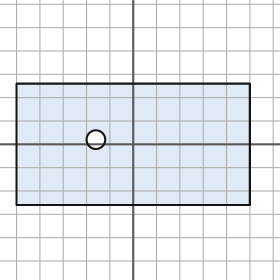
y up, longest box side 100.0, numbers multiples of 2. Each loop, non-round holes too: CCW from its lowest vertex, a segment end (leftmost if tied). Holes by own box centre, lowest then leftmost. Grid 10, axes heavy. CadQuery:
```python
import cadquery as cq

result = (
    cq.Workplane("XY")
    .moveTo(-50.0, -26.0)
    .lineTo(50.0, -26.0)
    .lineTo(50.0, 26.0)
    .lineTo(-50.0, 26.0)
    .close()
    .moveTo(-16.0, 2.0)
    .circle(4.0)
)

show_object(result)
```